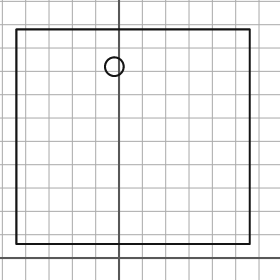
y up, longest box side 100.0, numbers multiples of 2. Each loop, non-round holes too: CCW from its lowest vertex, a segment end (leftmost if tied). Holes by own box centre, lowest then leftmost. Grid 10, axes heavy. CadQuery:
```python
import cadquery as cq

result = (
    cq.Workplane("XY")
    .moveTo(-44.0, 6.0)
    .lineTo(56.0, 6.0)
    .lineTo(56.0, 98.0)
    .lineTo(-44.0, 98.0)
    .close()
    .moveTo(-2.0, 82.0)
    .circle(4.0)
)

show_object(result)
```